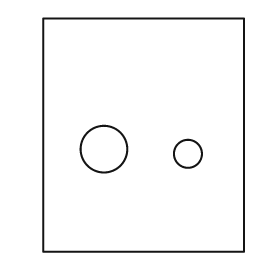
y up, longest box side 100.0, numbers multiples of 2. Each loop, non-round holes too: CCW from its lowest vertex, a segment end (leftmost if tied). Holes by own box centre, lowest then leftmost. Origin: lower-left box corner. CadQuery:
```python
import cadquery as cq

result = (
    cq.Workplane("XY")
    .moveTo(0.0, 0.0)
    .lineTo(86.0, 0.0)
    .lineTo(86.0, 100.0)
    .lineTo(0.0, 100.0)
    .close()
    .moveTo(62.0, 42.0)
    .circle(6.0)
    .moveTo(26.0, 44.0)
    .circle(10.0)
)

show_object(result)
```